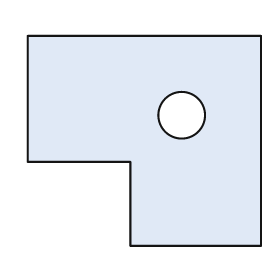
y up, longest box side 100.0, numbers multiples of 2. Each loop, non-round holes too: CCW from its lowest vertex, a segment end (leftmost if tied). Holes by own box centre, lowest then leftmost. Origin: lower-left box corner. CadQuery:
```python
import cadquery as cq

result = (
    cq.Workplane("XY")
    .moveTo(44.0, 0.0)
    .lineTo(100.0, 0.0)
    .lineTo(100.0, 90.0)
    .lineTo(0.0, 90.0)
    .lineTo(0.0, 36.0)
    .lineTo(44.0, 36.0)
    .close()
    .moveTo(66.0, 56.0)
    .circle(10.0)
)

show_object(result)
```